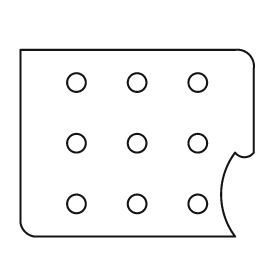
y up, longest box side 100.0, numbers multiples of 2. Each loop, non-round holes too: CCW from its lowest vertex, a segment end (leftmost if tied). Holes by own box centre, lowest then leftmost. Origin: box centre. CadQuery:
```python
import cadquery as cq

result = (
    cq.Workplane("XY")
    .moveTo(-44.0, -40.0)
    .lineTo(42.0, -40.0)
    .threePointArc((36.0, -22.0), (42.0, -4.0))
    .threePointArc((46.0, -6.0), (50.0, -4.0))
    .lineTo(50.0, 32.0)
    .threePointArc((48.0, 38.0), (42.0, 40.0))
    .lineTo(-50.0, 40.0)
    .lineTo(-50.0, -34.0)
    .threePointArc((-48.0, -38.0), (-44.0, -40.0))
    .close()
    .moveTo(-26.0, -26.0)
    .circle(4.0)
    .moveTo(0.0, -26.0)
    .circle(4.0)
    .moveTo(26.0, -26.0)
    .circle(4.0)
    .moveTo(-26.0, 0.0)
    .circle(4.0)
    .moveTo(0.0, 0.0)
    .circle(4.0)
    .moveTo(26.0, 0.0)
    .circle(4.0)
    .moveTo(-26.0, 26.0)
    .circle(4.0)
    .moveTo(0.0, 26.0)
    .circle(4.0)
    .moveTo(26.0, 26.0)
    .circle(4.0)
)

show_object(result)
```